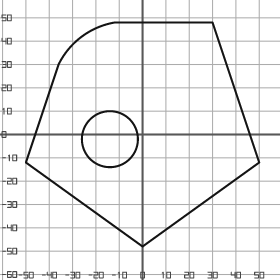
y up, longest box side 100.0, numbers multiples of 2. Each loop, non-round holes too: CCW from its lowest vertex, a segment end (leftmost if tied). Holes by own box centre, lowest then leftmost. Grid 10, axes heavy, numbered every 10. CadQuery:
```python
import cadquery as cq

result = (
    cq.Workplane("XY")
    .moveTo(0.0, -48.0)
    .lineTo(50.0, -12.0)
    .lineTo(30.0, 48.0)
    .lineTo(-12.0, 48.0)
    .threePointArc((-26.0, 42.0), (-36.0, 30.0))
    .lineTo(-50.0, -12.0)
    .close()
    .moveTo(-14.0, -2.0)
    .circle(12.0)
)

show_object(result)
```